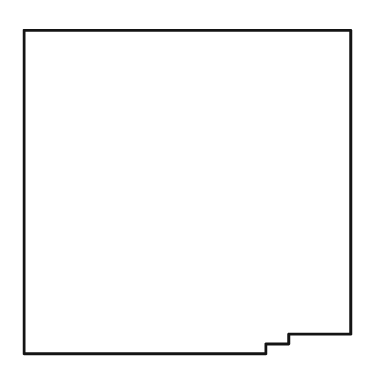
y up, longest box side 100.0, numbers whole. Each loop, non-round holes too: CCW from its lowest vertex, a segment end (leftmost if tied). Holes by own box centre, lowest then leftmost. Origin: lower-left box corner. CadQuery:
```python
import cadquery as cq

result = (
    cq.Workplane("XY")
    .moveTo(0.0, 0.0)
    .lineTo(74.0, 0.0)
    .lineTo(74.0, 3.0)
    .lineTo(81.0, 3.0)
    .lineTo(81.0, 6.0)
    .lineTo(100.0, 6.0)
    .lineTo(100.0, 99.0)
    .lineTo(0.0, 99.0)
    .close()
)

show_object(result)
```